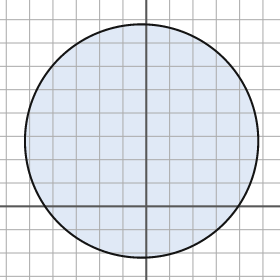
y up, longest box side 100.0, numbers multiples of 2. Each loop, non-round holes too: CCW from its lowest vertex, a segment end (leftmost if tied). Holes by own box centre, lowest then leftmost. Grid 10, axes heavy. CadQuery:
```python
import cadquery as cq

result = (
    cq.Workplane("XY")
    .moveTo(-2.0, 28.0)
    .circle(50.0)
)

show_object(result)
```